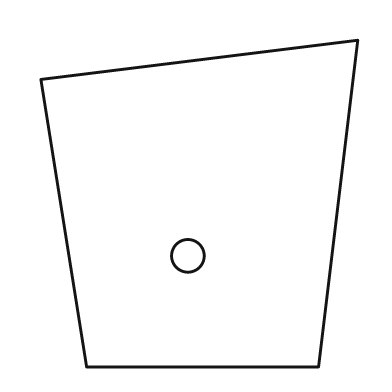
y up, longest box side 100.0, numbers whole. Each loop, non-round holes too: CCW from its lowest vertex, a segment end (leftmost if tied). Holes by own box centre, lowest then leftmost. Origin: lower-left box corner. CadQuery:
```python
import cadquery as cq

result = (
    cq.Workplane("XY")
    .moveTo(14.0, 0.0)
    .lineTo(85.0, 0.0)
    .lineTo(97.0, 100.0)
    .lineTo(0.0, 88.0)
    .close()
    .moveTo(45.0, 34.0)
    .circle(5.0)
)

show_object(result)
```